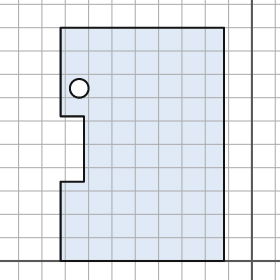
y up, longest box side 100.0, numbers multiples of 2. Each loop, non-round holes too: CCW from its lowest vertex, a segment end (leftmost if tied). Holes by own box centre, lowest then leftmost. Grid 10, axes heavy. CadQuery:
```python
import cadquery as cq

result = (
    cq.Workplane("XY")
    .moveTo(-82.0, 0.0)
    .lineTo(-12.0, 0.0)
    .lineTo(-12.0, 100.0)
    .lineTo(-82.0, 100.0)
    .lineTo(-82.0, 62.0)
    .lineTo(-72.0, 62.0)
    .lineTo(-72.0, 34.0)
    .lineTo(-82.0, 34.0)
    .close()
    .moveTo(-74.0, 74.0)
    .circle(4.0)
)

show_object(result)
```